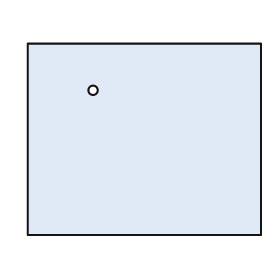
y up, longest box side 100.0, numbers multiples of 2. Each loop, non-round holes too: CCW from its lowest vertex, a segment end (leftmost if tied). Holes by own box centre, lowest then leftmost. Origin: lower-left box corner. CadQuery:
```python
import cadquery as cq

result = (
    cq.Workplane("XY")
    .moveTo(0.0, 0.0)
    .lineTo(100.0, 0.0)
    .lineTo(100.0, 82.0)
    .lineTo(0.0, 82.0)
    .close()
    .moveTo(28.0, 62.0)
    .circle(2.0)
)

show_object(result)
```